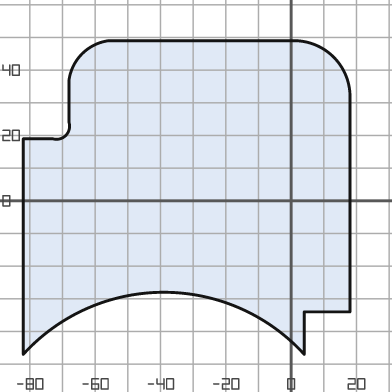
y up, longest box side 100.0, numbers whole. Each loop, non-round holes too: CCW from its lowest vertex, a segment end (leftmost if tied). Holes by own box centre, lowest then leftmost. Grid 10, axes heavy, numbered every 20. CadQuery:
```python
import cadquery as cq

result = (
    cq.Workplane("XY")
    .moveTo(-82.0, -47.0)
    .threePointArc((-39.0, -28.0), (4.0, -47.0))
    .lineTo(4.0, -34.0)
    .lineTo(18.0, -34.0)
    .lineTo(18.0, 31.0)
    .threePointArc((13.0, 44.0), (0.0, 49.0))
    .lineTo(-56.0, 49.0)
    .threePointArc((-64.0, 45.0), (-68.0, 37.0))
    .lineTo(-68.0, 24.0)
    .threePointArc((-69.0, 20.0), (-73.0, 19.0))
    .lineTo(-82.0, 19.0)
    .close()
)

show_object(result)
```